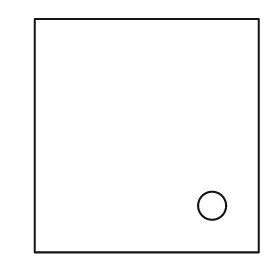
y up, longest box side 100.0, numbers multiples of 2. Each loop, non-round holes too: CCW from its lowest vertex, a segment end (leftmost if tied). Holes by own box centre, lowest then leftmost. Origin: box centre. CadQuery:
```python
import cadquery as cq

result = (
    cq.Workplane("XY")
    .moveTo(-48.0, -50.0)
    .lineTo(48.0, -50.0)
    .lineTo(48.0, 50.0)
    .lineTo(-48.0, 50.0)
    .close()
    .moveTo(28.0, -30.0)
    .circle(6.0)
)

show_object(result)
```